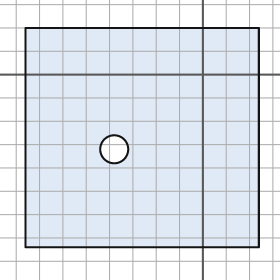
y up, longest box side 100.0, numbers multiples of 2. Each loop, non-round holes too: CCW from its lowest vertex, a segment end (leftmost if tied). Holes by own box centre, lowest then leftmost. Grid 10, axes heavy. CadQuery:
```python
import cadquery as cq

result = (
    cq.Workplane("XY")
    .moveTo(-76.0, -74.0)
    .lineTo(24.0, -74.0)
    .lineTo(24.0, 20.0)
    .lineTo(-76.0, 20.0)
    .close()
    .moveTo(-38.0, -32.0)
    .circle(6.0)
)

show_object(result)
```